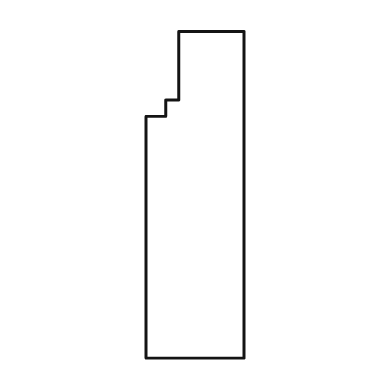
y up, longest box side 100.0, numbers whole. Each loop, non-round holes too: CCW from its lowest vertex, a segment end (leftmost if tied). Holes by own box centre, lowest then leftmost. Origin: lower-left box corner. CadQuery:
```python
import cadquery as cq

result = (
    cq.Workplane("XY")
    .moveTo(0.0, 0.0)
    .lineTo(30.0, 0.0)
    .lineTo(30.0, 100.0)
    .lineTo(10.0, 100.0)
    .lineTo(10.0, 79.0)
    .lineTo(6.0, 79.0)
    .lineTo(6.0, 74.0)
    .lineTo(0.0, 74.0)
    .close()
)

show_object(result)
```